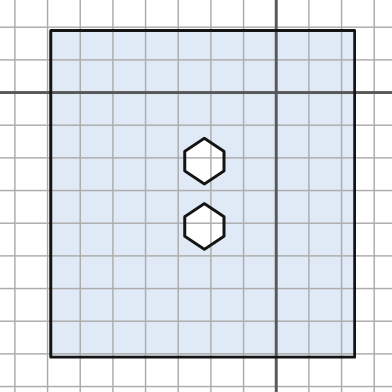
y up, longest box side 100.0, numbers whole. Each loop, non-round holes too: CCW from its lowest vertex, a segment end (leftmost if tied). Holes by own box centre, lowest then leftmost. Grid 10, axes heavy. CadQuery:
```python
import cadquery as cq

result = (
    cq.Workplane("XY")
    .moveTo(-69.0, -81.0)
    .lineTo(24.0, -81.0)
    .lineTo(24.0, 19.0)
    .lineTo(-69.0, 19.0)
    .close()
    .moveTo(-22.0, -48.0)
    .lineTo(-16.0, -44.0)
    .lineTo(-16.0, -38.0)
    .lineTo(-22.0, -34.0)
    .lineTo(-28.0, -38.0)
    .lineTo(-28.0, -44.0)
    .close()
    .moveTo(-22.0, -28.0)
    .lineTo(-16.0, -24.0)
    .lineTo(-16.0, -18.0)
    .lineTo(-22.0, -14.0)
    .lineTo(-28.0, -18.0)
    .lineTo(-28.0, -24.0)
    .close()
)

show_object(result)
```